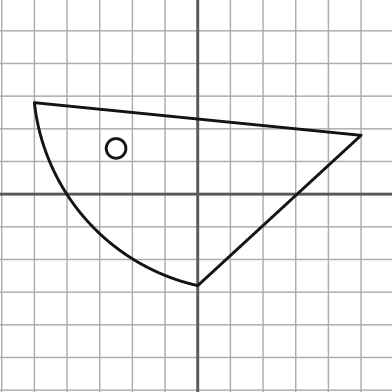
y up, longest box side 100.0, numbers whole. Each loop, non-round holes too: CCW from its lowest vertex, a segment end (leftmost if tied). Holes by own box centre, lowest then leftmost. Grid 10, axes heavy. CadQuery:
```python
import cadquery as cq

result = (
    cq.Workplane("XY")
    .moveTo(0.0, -28.0)
    .lineTo(50.0, 18.0)
    .lineTo(-50.0, 28.0)
    .threePointArc((-34.0, -8.0), (0.0, -28.0))
    .close()
    .moveTo(-25.0, 14.0)
    .circle(3.0)
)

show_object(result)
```